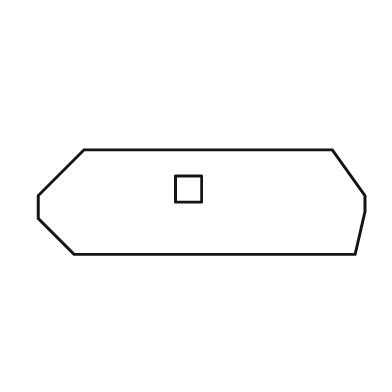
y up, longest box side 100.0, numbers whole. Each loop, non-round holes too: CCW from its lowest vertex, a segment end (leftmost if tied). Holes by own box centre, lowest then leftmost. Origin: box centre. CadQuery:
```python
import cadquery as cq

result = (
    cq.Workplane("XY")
    .moveTo(-39.0, -16.0)
    .lineTo(47.0, -16.0)
    .lineTo(50.0, -3.0)
    .lineTo(50.0, 2.0)
    .lineTo(40.0, 16.0)
    .lineTo(-36.0, 16.0)
    .lineTo(-50.0, 2.0)
    .lineTo(-50.0, -5.0)
    .close()
    .moveTo(-8.0, 0.0)
    .lineTo(0.0, 0.0)
    .lineTo(0.0, 8.0)
    .lineTo(-8.0, 8.0)
    .close()
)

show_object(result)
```